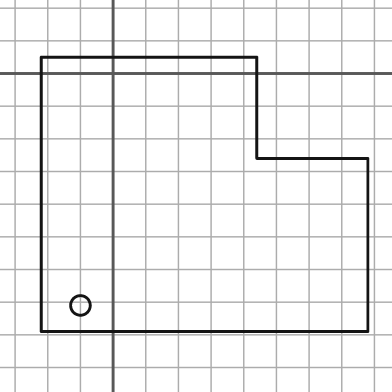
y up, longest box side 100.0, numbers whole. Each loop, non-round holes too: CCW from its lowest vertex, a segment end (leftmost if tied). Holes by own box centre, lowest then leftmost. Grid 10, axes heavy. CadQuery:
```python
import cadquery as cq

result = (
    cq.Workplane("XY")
    .moveTo(-22.0, -79.0)
    .lineTo(78.0, -79.0)
    .lineTo(78.0, -26.0)
    .lineTo(44.0, -26.0)
    .lineTo(44.0, 5.0)
    .lineTo(-22.0, 5.0)
    .close()
    .moveTo(-10.0, -71.0)
    .circle(3.0)
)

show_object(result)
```